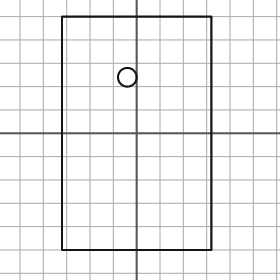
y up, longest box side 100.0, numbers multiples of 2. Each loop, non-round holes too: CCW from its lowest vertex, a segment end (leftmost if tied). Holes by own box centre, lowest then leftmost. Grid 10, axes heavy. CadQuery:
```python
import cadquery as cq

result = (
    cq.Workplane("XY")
    .moveTo(-32.0, -50.0)
    .lineTo(32.0, -50.0)
    .lineTo(32.0, 50.0)
    .lineTo(-32.0, 50.0)
    .close()
    .moveTo(-4.0, 24.0)
    .circle(4.0)
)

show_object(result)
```